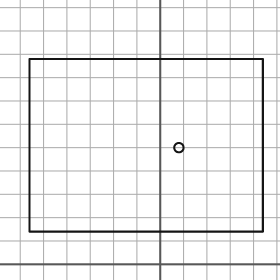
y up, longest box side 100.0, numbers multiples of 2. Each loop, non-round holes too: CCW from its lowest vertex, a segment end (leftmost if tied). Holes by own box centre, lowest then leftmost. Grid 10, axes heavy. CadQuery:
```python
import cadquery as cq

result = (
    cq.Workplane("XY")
    .moveTo(-56.0, 14.0)
    .lineTo(44.0, 14.0)
    .lineTo(44.0, 88.0)
    .lineTo(-56.0, 88.0)
    .close()
    .moveTo(8.0, 50.0)
    .circle(2.0)
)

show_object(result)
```